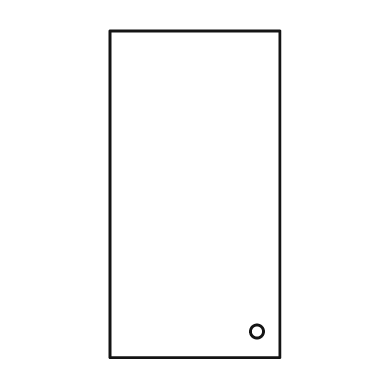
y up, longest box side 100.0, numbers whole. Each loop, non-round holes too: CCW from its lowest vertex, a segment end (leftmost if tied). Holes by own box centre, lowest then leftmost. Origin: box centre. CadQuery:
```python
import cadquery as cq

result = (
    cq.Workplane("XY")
    .moveTo(-26.0, -50.0)
    .lineTo(26.0, -50.0)
    .lineTo(26.0, 50.0)
    .lineTo(-26.0, 50.0)
    .close()
    .moveTo(19.0, -42.0)
    .circle(2.0)
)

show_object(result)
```